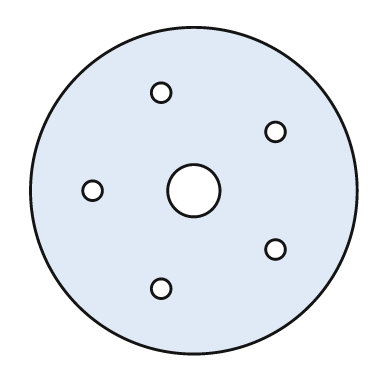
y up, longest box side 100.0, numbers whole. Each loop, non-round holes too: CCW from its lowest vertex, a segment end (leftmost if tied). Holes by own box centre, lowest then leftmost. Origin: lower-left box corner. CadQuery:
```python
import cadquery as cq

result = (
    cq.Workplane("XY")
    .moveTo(50.0, 50.0)
    .circle(50.0)
    .moveTo(40.0, 20.0)
    .circle(3.0)
    .moveTo(75.0, 32.0)
    .circle(3.0)
    .moveTo(19.0, 50.0)
    .circle(3.0)
    .moveTo(50.0, 50.0)
    .circle(8.0)
    .moveTo(75.0, 68.0)
    .circle(3.0)
    .moveTo(40.0, 80.0)
    .circle(3.0)
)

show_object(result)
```